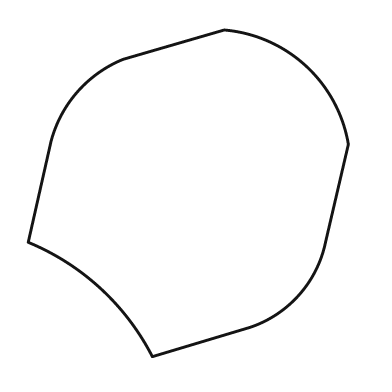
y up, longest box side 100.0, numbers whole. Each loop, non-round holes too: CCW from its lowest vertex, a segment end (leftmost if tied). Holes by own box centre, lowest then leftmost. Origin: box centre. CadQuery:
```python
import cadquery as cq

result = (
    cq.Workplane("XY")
    .moveTo(-11.0, -50.0)
    .lineTo(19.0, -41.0)
    .threePointArc((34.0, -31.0), (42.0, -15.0))
    .lineTo(49.0, 15.0)
    .threePointArc((36.0, 39.0), (11.0, 50.0))
    .lineTo(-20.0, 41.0)
    .threePointArc((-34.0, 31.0), (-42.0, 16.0))
    .lineTo(-49.0, -15.0)
    .threePointArc((-27.0, -29.0), (-11.0, -50.0))
    .close()
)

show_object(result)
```